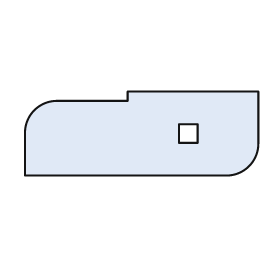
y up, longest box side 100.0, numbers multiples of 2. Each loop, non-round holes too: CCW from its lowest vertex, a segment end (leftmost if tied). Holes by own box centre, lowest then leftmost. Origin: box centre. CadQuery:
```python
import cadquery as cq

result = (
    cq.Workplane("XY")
    .moveTo(-50.0, -18.0)
    .lineTo(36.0, -18.0)
    .threePointArc((46.0, -14.0), (50.0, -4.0))
    .lineTo(50.0, 18.0)
    .lineTo(-6.0, 18.0)
    .lineTo(-6.0, 14.0)
    .lineTo(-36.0, 14.0)
    .threePointArc((-46.0, 10.0), (-50.0, 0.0))
    .close()
    .moveTo(16.0, -4.0)
    .lineTo(24.0, -4.0)
    .lineTo(24.0, 4.0)
    .lineTo(16.0, 4.0)
    .close()
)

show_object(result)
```